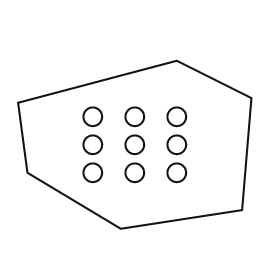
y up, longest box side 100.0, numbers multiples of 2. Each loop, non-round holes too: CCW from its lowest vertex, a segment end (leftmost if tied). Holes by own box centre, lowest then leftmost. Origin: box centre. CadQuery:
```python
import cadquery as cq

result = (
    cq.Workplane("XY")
    .moveTo(-6.0, -36.0)
    .lineTo(46.0, -28.0)
    .lineTo(50.0, 20.0)
    .lineTo(18.0, 36.0)
    .lineTo(-50.0, 18.0)
    .lineTo(-46.0, -12.0)
    .close()
    .moveTo(-18.0, -12.0)
    .circle(4.0)
    .moveTo(0.0, -12.0)
    .circle(4.0)
    .moveTo(18.0, -12.0)
    .circle(4.0)
    .moveTo(-18.0, 0.0)
    .circle(4.0)
    .moveTo(0.0, 0.0)
    .circle(4.0)
    .moveTo(18.0, 0.0)
    .circle(4.0)
    .moveTo(-18.0, 12.0)
    .circle(4.0)
    .moveTo(0.0, 12.0)
    .circle(4.0)
    .moveTo(18.0, 12.0)
    .circle(4.0)
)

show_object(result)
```